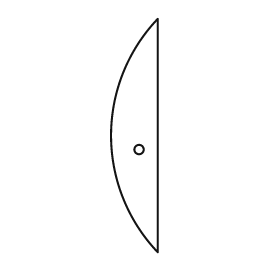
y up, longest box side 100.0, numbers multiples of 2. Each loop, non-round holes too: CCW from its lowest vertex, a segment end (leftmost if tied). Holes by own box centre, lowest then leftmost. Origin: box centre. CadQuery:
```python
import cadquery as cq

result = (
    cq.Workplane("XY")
    .moveTo(10.0, -50.0)
    .lineTo(10.0, 50.0)
    .threePointArc((-10.0, 0.0), (10.0, -50.0))
    .close()
    .moveTo(2.0, -6.0)
    .circle(2.0)
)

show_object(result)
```